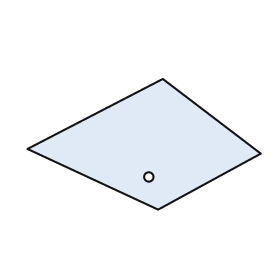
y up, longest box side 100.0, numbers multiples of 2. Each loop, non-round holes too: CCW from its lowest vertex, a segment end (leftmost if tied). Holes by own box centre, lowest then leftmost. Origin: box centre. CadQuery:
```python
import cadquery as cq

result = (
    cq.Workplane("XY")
    .moveTo(6.0, -28.0)
    .lineTo(50.0, -4.0)
    .lineTo(8.0, 28.0)
    .lineTo(-50.0, -2.0)
    .close()
    .moveTo(2.0, -14.0)
    .circle(2.0)
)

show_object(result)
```